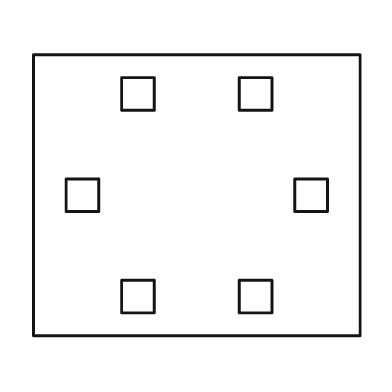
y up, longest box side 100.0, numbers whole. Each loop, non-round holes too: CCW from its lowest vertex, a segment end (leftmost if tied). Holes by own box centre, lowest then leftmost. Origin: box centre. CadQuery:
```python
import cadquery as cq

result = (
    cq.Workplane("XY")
    .moveTo(-50.0, -43.0)
    .lineTo(50.0, -43.0)
    .lineTo(50.0, 43.0)
    .lineTo(-50.0, 43.0)
    .close()
    .moveTo(-23.0, -36.0)
    .lineTo(-13.0, -36.0)
    .lineTo(-13.0, -26.0)
    .lineTo(-23.0, -26.0)
    .close()
    .moveTo(13.0, -36.0)
    .lineTo(23.0, -36.0)
    .lineTo(23.0, -26.0)
    .lineTo(13.0, -26.0)
    .close()
    .moveTo(-40.0, -5.0)
    .lineTo(-30.0, -5.0)
    .lineTo(-30.0, 5.0)
    .lineTo(-40.0, 5.0)
    .close()
    .moveTo(30.0, -5.0)
    .lineTo(40.0, -5.0)
    .lineTo(40.0, 5.0)
    .lineTo(30.0, 5.0)
    .close()
    .moveTo(-23.0, 26.0)
    .lineTo(-13.0, 26.0)
    .lineTo(-13.0, 36.0)
    .lineTo(-23.0, 36.0)
    .close()
    .moveTo(13.0, 26.0)
    .lineTo(23.0, 26.0)
    .lineTo(23.0, 36.0)
    .lineTo(13.0, 36.0)
    .close()
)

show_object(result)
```